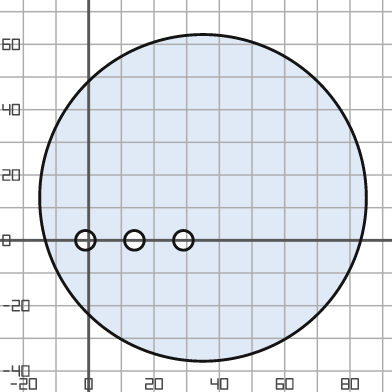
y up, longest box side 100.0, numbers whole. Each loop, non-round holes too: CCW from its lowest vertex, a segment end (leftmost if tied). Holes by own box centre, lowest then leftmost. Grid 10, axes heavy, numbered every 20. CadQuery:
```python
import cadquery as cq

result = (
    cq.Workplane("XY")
    .moveTo(35.0, 13.0)
    .circle(50.0)
    .moveTo(-1.0, 0.0)
    .circle(3.0)
    .moveTo(14.0, 0.0)
    .circle(3.0)
    .moveTo(29.0, 0.0)
    .circle(3.0)
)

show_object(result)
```